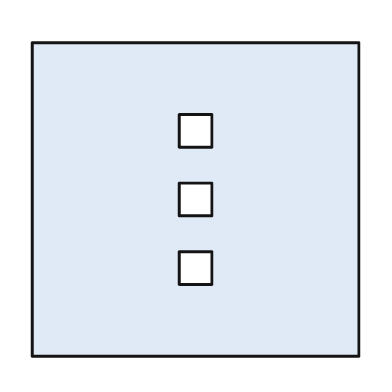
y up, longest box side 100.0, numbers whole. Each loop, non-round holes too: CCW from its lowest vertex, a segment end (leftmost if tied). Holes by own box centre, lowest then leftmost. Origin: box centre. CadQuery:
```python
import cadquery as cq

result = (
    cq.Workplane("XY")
    .moveTo(-50.0, -48.0)
    .lineTo(50.0, -48.0)
    .lineTo(50.0, 48.0)
    .lineTo(-50.0, 48.0)
    .close()
    .moveTo(-5.0, -26.0)
    .lineTo(5.0, -26.0)
    .lineTo(5.0, -16.0)
    .lineTo(-5.0, -16.0)
    .close()
    .moveTo(-5.0, -5.0)
    .lineTo(5.0, -5.0)
    .lineTo(5.0, 5.0)
    .lineTo(-5.0, 5.0)
    .close()
    .moveTo(-5.0, 16.0)
    .lineTo(5.0, 16.0)
    .lineTo(5.0, 26.0)
    .lineTo(-5.0, 26.0)
    .close()
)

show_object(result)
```